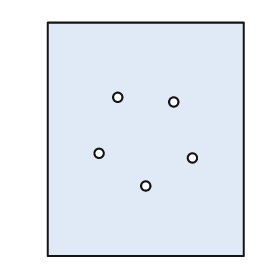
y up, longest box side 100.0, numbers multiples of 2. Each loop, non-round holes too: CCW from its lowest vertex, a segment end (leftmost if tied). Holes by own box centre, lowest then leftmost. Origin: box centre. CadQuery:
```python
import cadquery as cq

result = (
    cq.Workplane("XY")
    .moveTo(-42.0, -50.0)
    .lineTo(42.0, -50.0)
    .lineTo(42.0, 50.0)
    .lineTo(-42.0, 50.0)
    .close()
    .moveTo(0.0, -20.0)
    .circle(2.0)
    .moveTo(20.0, -8.0)
    .circle(2.0)
    .moveTo(-20.0, -6.0)
    .circle(2.0)
    .moveTo(12.0, 16.0)
    .circle(2.0)
    .moveTo(-12.0, 18.0)
    .circle(2.0)
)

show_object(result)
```